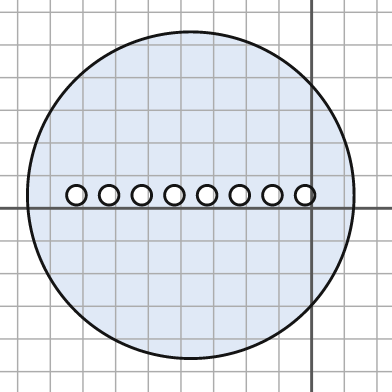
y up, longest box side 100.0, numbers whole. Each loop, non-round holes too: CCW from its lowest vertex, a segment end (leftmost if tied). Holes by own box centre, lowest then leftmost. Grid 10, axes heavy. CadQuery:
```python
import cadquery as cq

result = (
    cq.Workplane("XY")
    .moveTo(-37.0, 4.0)
    .circle(50.0)
    .moveTo(-72.0, 4.0)
    .circle(3.0)
    .moveTo(-62.0, 4.0)
    .circle(3.0)
    .moveTo(-52.0, 4.0)
    .circle(3.0)
    .moveTo(-42.0, 4.0)
    .circle(3.0)
    .moveTo(-32.0, 4.0)
    .circle(3.0)
    .moveTo(-22.0, 4.0)
    .circle(3.0)
    .moveTo(-12.0, 4.0)
    .circle(3.0)
    .moveTo(-2.0, 4.0)
    .circle(3.0)
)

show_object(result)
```